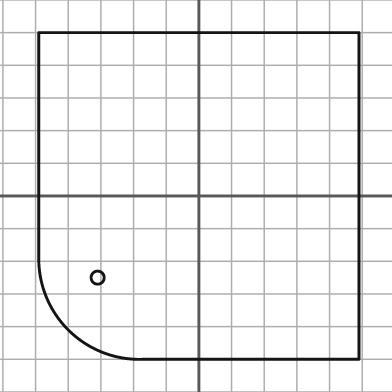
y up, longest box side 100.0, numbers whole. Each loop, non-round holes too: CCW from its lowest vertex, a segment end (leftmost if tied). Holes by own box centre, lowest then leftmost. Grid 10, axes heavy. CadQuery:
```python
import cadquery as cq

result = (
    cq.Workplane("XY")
    .moveTo(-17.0, -50.0)
    .lineTo(49.0, -50.0)
    .lineTo(49.0, 50.0)
    .lineTo(-49.0, 50.0)
    .lineTo(-49.0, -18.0)
    .threePointArc((-40.0, -41.0), (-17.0, -50.0))
    .close()
    .moveTo(-31.0, -25.0)
    .circle(2.0)
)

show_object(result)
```